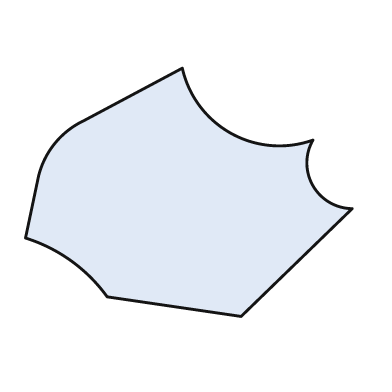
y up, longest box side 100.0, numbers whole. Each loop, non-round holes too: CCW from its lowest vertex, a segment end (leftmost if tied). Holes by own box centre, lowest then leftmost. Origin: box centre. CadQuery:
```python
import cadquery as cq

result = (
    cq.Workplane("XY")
    .moveTo(16.0, -38.0)
    .lineTo(50.0, -5.0)
    .threePointArc((38.0, 2.0), (38.0, 16.0))
    .threePointArc((13.0, 18.0), (-2.0, 38.0))
    .lineTo(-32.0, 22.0)
    .threePointArc((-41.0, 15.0), (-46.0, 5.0))
    .lineTo(-50.0, -14.0)
    .threePointArc((-36.0, -21.0), (-25.0, -32.0))
    .close()
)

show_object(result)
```